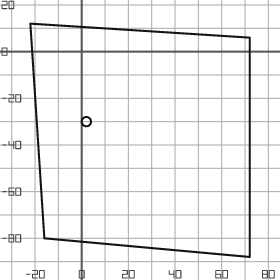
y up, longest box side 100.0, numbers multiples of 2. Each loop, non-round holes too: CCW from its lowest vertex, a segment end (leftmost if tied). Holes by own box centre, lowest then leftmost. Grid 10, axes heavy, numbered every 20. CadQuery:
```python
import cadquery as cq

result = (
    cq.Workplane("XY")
    .moveTo(72.0, -88.0)
    .lineTo(72.0, 6.0)
    .lineTo(-22.0, 12.0)
    .lineTo(-16.0, -80.0)
    .close()
    .moveTo(2.0, -30.0)
    .circle(2.0)
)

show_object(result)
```